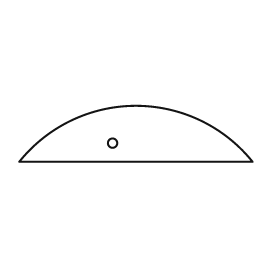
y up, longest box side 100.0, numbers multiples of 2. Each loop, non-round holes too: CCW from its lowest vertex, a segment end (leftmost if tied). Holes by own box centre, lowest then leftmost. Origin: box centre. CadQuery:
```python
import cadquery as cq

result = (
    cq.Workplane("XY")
    .moveTo(-50.0, -12.0)
    .lineTo(50.0, -12.0)
    .threePointArc((0.0, 12.0), (-50.0, -12.0))
    .close()
    .moveTo(-10.0, -4.0)
    .circle(2.0)
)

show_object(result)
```